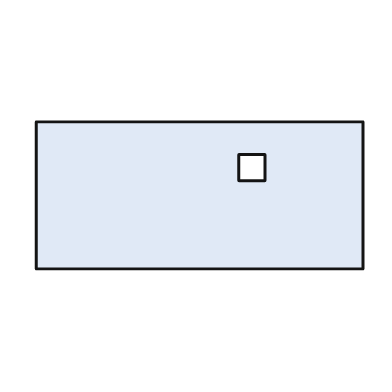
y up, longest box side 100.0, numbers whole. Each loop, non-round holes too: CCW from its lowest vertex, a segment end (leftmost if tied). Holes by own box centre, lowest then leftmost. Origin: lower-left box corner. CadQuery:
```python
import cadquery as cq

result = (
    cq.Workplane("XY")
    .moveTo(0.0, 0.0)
    .lineTo(100.0, 0.0)
    .lineTo(100.0, 45.0)
    .lineTo(0.0, 45.0)
    .close()
    .moveTo(62.0, 27.0)
    .lineTo(70.0, 27.0)
    .lineTo(70.0, 35.0)
    .lineTo(62.0, 35.0)
    .close()
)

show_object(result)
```